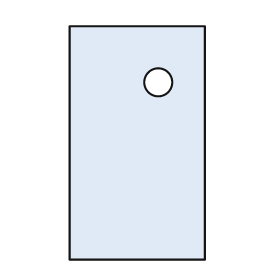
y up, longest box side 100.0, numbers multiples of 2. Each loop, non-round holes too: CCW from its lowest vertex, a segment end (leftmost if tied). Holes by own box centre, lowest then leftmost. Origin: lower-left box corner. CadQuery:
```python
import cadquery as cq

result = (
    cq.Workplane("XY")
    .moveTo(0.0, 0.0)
    .lineTo(58.0, 0.0)
    .lineTo(58.0, 100.0)
    .lineTo(0.0, 100.0)
    .close()
    .moveTo(38.0, 76.0)
    .circle(6.0)
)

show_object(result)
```